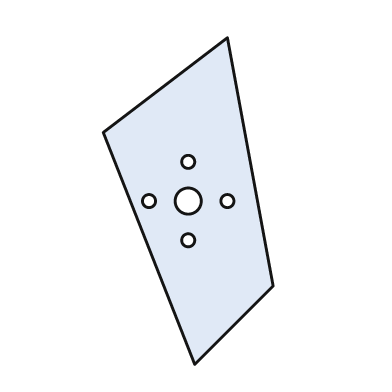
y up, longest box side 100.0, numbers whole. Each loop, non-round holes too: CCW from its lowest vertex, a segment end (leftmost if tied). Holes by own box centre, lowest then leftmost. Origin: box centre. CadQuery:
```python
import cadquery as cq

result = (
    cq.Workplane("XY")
    .moveTo(2.0, -50.0)
    .lineTo(26.0, -26.0)
    .lineTo(12.0, 50.0)
    .lineTo(-26.0, 21.0)
    .close()
    .moveTo(0.0, -12.0)
    .circle(2.0)
    .moveTo(-12.0, 0.0)
    .circle(2.0)
    .moveTo(0.0, 0.0)
    .circle(4.0)
    .moveTo(12.0, 0.0)
    .circle(2.0)
    .moveTo(0.0, 12.0)
    .circle(2.0)
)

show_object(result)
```